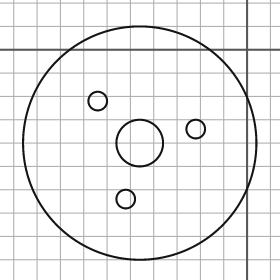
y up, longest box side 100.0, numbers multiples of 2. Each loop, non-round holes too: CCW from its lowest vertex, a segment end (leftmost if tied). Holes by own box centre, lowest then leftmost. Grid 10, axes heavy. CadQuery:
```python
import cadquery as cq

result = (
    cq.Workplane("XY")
    .moveTo(-46.0, -40.0)
    .circle(50.0)
    .moveTo(-52.0, -64.0)
    .circle(4.0)
    .moveTo(-46.0, -40.0)
    .circle(10.0)
    .moveTo(-22.0, -34.0)
    .circle(4.0)
    .moveTo(-64.0, -22.0)
    .circle(4.0)
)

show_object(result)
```